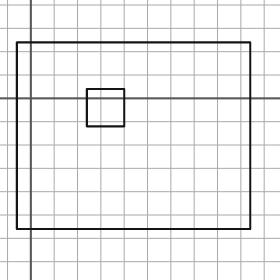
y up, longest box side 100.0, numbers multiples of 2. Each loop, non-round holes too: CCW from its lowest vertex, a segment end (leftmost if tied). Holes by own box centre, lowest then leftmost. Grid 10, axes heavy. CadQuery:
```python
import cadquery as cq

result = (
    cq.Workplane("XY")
    .moveTo(-6.0, -56.0)
    .lineTo(94.0, -56.0)
    .lineTo(94.0, 24.0)
    .lineTo(-6.0, 24.0)
    .close()
    .moveTo(24.0, -12.0)
    .lineTo(40.0, -12.0)
    .lineTo(40.0, 4.0)
    .lineTo(24.0, 4.0)
    .close()
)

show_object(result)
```